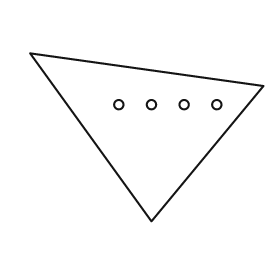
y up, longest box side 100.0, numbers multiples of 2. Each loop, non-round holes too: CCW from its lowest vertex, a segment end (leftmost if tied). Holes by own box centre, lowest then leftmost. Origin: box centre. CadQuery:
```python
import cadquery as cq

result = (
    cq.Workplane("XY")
    .moveTo(2.0, -36.0)
    .lineTo(50.0, 22.0)
    .lineTo(-50.0, 36.0)
    .close()
    .moveTo(-12.0, 14.0)
    .circle(2.0)
    .moveTo(2.0, 14.0)
    .circle(2.0)
    .moveTo(16.0, 14.0)
    .circle(2.0)
    .moveTo(30.0, 14.0)
    .circle(2.0)
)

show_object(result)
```